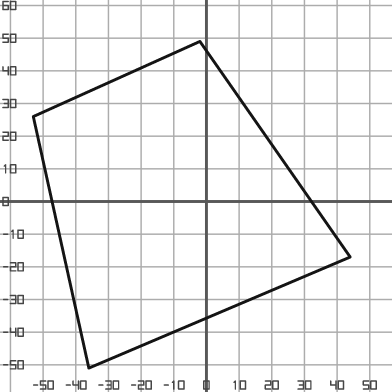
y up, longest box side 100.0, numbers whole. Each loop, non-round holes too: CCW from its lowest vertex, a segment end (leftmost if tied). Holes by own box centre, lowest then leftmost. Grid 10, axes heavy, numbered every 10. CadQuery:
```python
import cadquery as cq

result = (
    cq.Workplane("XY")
    .moveTo(-36.0, -51.0)
    .lineTo(44.0, -17.0)
    .lineTo(-2.0, 49.0)
    .lineTo(-53.0, 26.0)
    .close()
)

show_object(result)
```